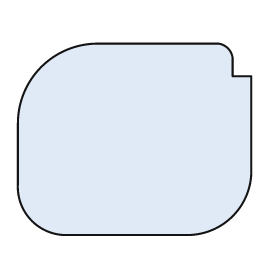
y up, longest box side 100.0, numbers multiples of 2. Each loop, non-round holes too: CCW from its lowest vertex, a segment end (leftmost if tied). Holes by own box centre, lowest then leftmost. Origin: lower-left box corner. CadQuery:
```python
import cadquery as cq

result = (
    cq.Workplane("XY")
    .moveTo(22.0, 0.0)
    .lineTo(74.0, 0.0)
    .threePointArc((92.0, 8.0), (100.0, 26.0))
    .lineTo(100.0, 68.0)
    .lineTo(92.0, 68.0)
    .lineTo(92.0, 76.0)
    .threePointArc((90.0, 80.0), (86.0, 82.0))
    .lineTo(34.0, 82.0)
    .threePointArc((10.0, 72.0), (0.0, 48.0))
    .lineTo(0.0, 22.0)
    .threePointArc((6.0, 6.0), (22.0, 0.0))
    .close()
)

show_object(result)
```